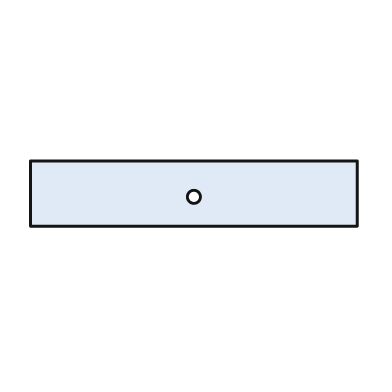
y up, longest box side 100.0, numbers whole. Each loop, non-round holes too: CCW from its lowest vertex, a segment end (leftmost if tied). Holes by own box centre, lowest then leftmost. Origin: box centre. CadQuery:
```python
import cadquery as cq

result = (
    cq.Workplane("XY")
    .moveTo(-50.0, -10.0)
    .lineTo(50.0, -10.0)
    .lineTo(50.0, 10.0)
    .lineTo(-50.0, 10.0)
    .close()
    .moveTo(0.0, -1.0)
    .circle(2.0)
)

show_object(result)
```